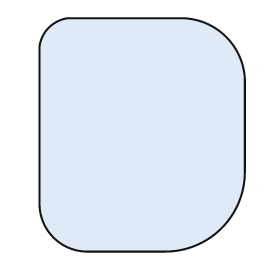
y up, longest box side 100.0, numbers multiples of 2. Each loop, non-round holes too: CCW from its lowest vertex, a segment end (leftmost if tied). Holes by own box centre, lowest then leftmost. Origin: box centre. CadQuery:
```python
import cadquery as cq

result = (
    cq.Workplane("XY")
    .moveTo(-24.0, -50.0)
    .lineTo(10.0, -50.0)
    .threePointArc((34.0, -40.0), (44.0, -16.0))
    .lineTo(44.0, 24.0)
    .threePointArc((36.0, 42.0), (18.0, 50.0))
    .lineTo(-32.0, 50.0)
    .threePointArc((-40.0, 46.0), (-44.0, 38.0))
    .lineTo(-44.0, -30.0)
    .threePointArc((-38.0, -44.0), (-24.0, -50.0))
    .close()
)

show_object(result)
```